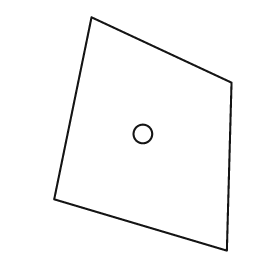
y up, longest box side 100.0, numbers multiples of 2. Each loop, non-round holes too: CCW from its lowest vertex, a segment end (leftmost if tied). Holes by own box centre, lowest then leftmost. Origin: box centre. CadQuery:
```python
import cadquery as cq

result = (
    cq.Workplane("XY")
    .moveTo(36.0, -50.0)
    .lineTo(38.0, 22.0)
    .lineTo(-22.0, 50.0)
    .lineTo(-38.0, -28.0)
    .close()
    .moveTo(0.0, 0.0)
    .circle(4.0)
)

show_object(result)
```